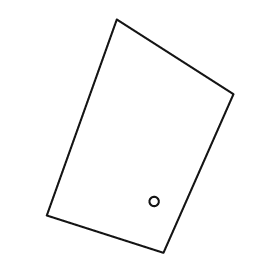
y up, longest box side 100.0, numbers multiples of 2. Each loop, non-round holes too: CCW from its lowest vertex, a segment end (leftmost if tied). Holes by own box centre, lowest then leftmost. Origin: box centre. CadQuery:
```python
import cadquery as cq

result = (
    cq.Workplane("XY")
    .moveTo(10.0, -50.0)
    .lineTo(40.0, 18.0)
    .lineTo(-10.0, 50.0)
    .lineTo(-40.0, -34.0)
    .close()
    .moveTo(6.0, -28.0)
    .circle(2.0)
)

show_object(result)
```